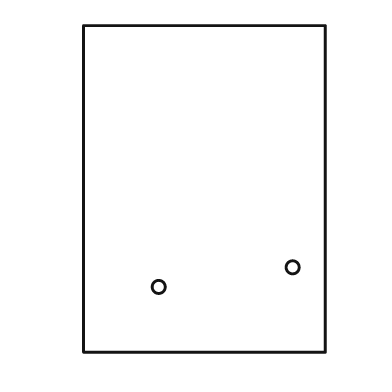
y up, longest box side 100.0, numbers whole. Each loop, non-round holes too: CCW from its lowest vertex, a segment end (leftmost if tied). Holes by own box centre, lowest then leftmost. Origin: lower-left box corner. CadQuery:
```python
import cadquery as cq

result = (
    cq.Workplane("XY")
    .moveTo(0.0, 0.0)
    .lineTo(74.0, 0.0)
    .lineTo(74.0, 100.0)
    .lineTo(0.0, 100.0)
    .close()
    .moveTo(23.0, 20.0)
    .circle(2.0)
    .moveTo(64.0, 26.0)
    .circle(2.0)
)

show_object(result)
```